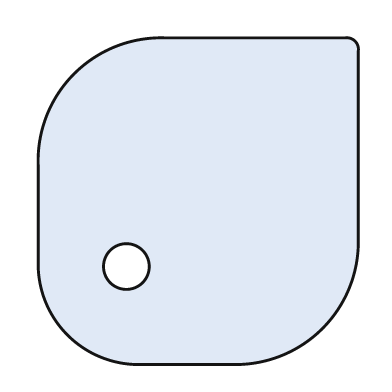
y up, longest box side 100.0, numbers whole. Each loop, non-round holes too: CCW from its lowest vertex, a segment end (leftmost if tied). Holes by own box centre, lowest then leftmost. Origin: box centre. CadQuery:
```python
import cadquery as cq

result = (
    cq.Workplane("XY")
    .moveTo(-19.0, -50.0)
    .lineTo(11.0, -50.0)
    .threePointArc((38.0, -39.0), (49.0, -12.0))
    .lineTo(49.0, 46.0)
    .threePointArc((48.0, 49.0), (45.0, 50.0))
    .lineTo(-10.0, 50.0)
    .threePointArc((-38.0, 39.0), (-49.0, 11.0))
    .lineTo(-49.0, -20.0)
    .threePointArc((-40.0, -41.0), (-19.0, -50.0))
    .close()
    .moveTo(-22.0, -20.0)
    .circle(7.0)
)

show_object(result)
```